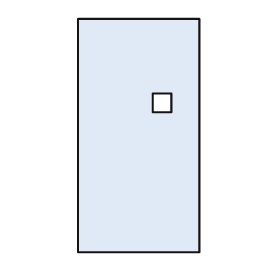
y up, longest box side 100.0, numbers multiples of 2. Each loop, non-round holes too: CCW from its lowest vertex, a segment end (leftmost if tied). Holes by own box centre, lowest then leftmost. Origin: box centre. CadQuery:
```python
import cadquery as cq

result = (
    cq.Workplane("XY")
    .moveTo(-26.0, -50.0)
    .lineTo(26.0, -50.0)
    .lineTo(26.0, 50.0)
    .lineTo(-26.0, 50.0)
    .close()
    .moveTo(6.0, 10.0)
    .lineTo(14.0, 10.0)
    .lineTo(14.0, 18.0)
    .lineTo(6.0, 18.0)
    .close()
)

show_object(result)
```